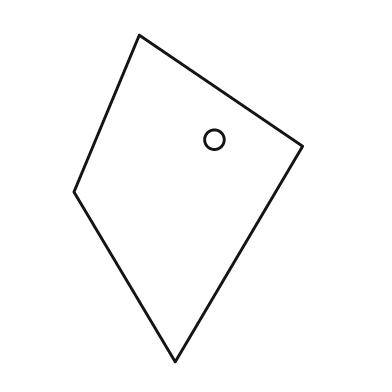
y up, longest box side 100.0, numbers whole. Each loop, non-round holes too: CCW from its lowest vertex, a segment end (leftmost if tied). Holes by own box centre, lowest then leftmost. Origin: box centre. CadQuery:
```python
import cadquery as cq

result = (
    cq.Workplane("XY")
    .moveTo(-4.0, -50.0)
    .lineTo(35.0, 16.0)
    .lineTo(-15.0, 50.0)
    .lineTo(-35.0, 2.0)
    .close()
    .moveTo(8.0, 18.0)
    .circle(3.0)
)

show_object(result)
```